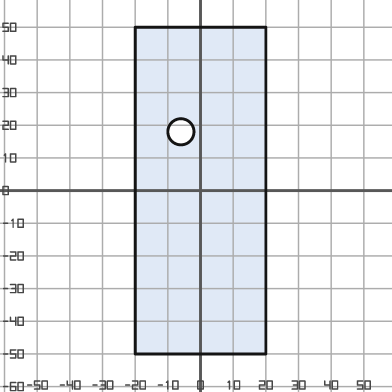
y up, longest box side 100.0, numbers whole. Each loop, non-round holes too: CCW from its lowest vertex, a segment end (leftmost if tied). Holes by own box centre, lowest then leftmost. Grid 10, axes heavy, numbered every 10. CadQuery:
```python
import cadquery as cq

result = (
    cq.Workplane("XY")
    .moveTo(-20.0, -50.0)
    .lineTo(20.0, -50.0)
    .lineTo(20.0, 50.0)
    .lineTo(-20.0, 50.0)
    .close()
    .moveTo(-6.0, 18.0)
    .circle(4.0)
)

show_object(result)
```